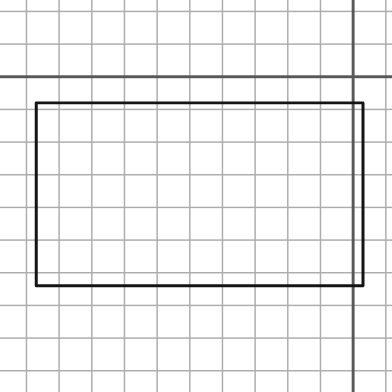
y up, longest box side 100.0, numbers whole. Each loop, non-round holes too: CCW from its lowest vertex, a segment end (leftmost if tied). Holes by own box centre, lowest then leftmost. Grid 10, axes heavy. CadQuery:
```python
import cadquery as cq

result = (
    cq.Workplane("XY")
    .moveTo(-97.0, -64.0)
    .lineTo(3.0, -64.0)
    .lineTo(3.0, -8.0)
    .lineTo(-97.0, -8.0)
    .close()
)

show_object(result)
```